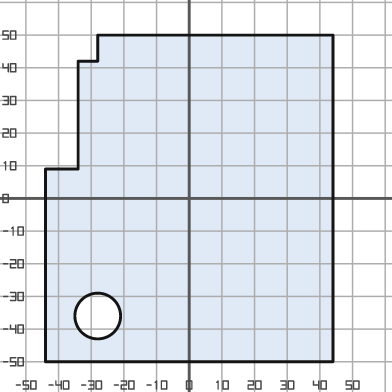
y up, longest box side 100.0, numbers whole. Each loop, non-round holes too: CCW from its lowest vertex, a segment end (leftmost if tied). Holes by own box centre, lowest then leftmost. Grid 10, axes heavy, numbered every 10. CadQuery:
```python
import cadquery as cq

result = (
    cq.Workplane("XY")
    .moveTo(-44.0, -50.0)
    .lineTo(44.0, -50.0)
    .lineTo(44.0, 50.0)
    .lineTo(-28.0, 50.0)
    .lineTo(-28.0, 42.0)
    .lineTo(-34.0, 42.0)
    .lineTo(-34.0, 9.0)
    .lineTo(-44.0, 9.0)
    .close()
    .moveTo(-28.0, -36.0)
    .circle(7.0)
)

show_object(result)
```